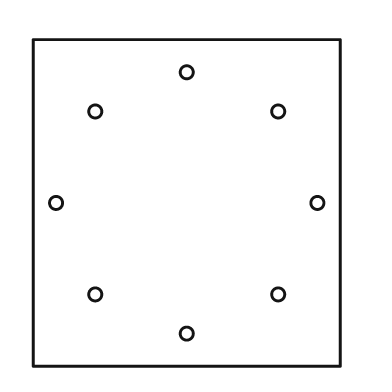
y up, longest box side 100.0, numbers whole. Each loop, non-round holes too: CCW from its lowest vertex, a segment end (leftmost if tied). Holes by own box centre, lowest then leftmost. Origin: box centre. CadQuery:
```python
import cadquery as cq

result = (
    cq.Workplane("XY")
    .moveTo(-47.0, -50.0)
    .lineTo(47.0, -50.0)
    .lineTo(47.0, 50.0)
    .lineTo(-47.0, 50.0)
    .close()
    .moveTo(0.0, -40.0)
    .circle(2.0)
    .moveTo(-28.0, -28.0)
    .circle(2.0)
    .moveTo(28.0, -28.0)
    .circle(2.0)
    .moveTo(-40.0, 0.0)
    .circle(2.0)
    .moveTo(40.0, 0.0)
    .circle(2.0)
    .moveTo(-28.0, 28.0)
    .circle(2.0)
    .moveTo(28.0, 28.0)
    .circle(2.0)
    .moveTo(0.0, 40.0)
    .circle(2.0)
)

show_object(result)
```